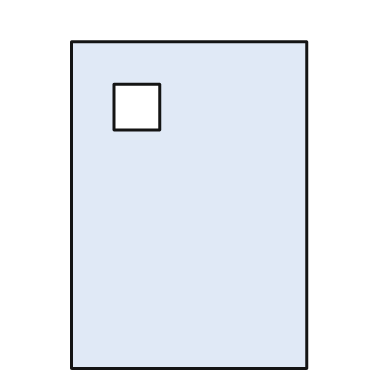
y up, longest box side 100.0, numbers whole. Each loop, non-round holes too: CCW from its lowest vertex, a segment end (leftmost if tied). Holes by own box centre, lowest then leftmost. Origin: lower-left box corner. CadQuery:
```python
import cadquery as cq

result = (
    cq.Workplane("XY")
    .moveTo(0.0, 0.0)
    .lineTo(72.0, 0.0)
    .lineTo(72.0, 100.0)
    .lineTo(0.0, 100.0)
    .close()
    .moveTo(13.0, 73.0)
    .lineTo(27.0, 73.0)
    .lineTo(27.0, 87.0)
    .lineTo(13.0, 87.0)
    .close()
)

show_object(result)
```